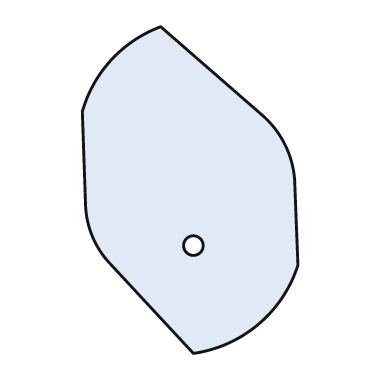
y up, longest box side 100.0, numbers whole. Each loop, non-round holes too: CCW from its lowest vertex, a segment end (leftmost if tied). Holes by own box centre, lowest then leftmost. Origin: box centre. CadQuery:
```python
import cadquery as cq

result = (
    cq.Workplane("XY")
    .moveTo(1.0, -50.0)
    .threePointArc((21.0, -41.0), (33.0, -23.0))
    .lineTo(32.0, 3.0)
    .threePointArc((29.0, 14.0), (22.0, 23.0))
    .lineTo(-9.0, 50.0)
    .threePointArc((-24.0, 40.0), (-33.0, 24.0))
    .lineTo(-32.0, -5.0)
    .threePointArc((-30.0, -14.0), (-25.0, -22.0))
    .close()
    .moveTo(1.0, -17.0)
    .circle(3.0)
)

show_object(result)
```